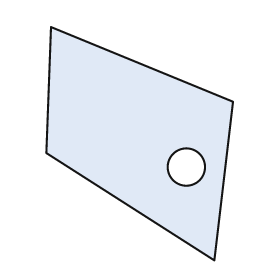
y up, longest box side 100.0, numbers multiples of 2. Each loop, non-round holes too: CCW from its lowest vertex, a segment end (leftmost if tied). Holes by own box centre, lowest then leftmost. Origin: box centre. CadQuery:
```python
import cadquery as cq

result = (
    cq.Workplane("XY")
    .moveTo(32.0, -50.0)
    .lineTo(40.0, 18.0)
    .lineTo(-38.0, 50.0)
    .lineTo(-40.0, -4.0)
    .close()
    .moveTo(20.0, -10.0)
    .circle(8.0)
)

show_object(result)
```